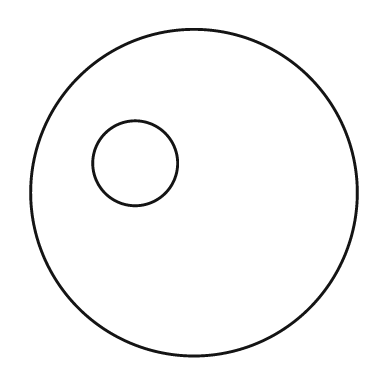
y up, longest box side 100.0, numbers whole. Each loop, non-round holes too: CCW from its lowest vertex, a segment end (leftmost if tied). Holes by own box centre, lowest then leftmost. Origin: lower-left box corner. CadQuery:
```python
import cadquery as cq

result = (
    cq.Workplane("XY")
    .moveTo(50.0, 50.0)
    .circle(50.0)
    .moveTo(32.0, 59.0)
    .circle(13.0)
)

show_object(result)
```